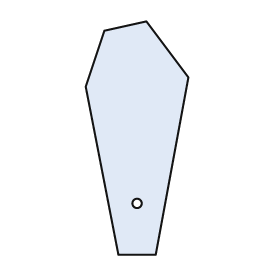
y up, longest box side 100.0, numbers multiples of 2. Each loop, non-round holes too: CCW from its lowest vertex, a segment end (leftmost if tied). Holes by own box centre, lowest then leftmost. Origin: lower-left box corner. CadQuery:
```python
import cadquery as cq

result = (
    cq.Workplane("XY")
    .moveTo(14.0, 0.0)
    .lineTo(30.0, 0.0)
    .lineTo(44.0, 76.0)
    .lineTo(26.0, 100.0)
    .lineTo(8.0, 96.0)
    .lineTo(0.0, 72.0)
    .close()
    .moveTo(22.0, 22.0)
    .circle(2.0)
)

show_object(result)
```